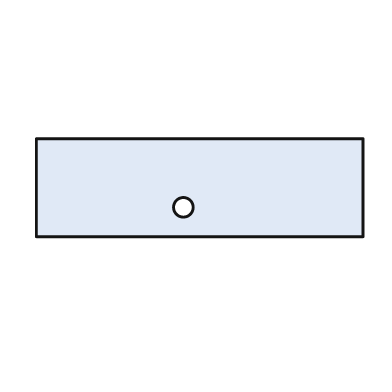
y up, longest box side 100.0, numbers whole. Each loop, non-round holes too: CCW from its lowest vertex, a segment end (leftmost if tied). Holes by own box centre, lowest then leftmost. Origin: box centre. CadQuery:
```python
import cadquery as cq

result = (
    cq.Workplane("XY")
    .moveTo(-50.0, -15.0)
    .lineTo(50.0, -15.0)
    .lineTo(50.0, 15.0)
    .lineTo(-50.0, 15.0)
    .close()
    .moveTo(-5.0, -6.0)
    .circle(3.0)
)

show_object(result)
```